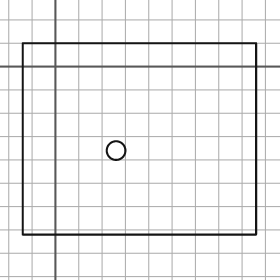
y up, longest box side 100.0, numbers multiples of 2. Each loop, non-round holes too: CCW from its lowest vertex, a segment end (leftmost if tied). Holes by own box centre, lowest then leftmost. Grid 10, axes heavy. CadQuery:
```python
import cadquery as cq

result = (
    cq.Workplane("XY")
    .moveTo(-14.0, -72.0)
    .lineTo(86.0, -72.0)
    .lineTo(86.0, 10.0)
    .lineTo(-14.0, 10.0)
    .close()
    .moveTo(26.0, -36.0)
    .circle(4.0)
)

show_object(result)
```